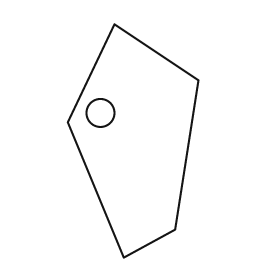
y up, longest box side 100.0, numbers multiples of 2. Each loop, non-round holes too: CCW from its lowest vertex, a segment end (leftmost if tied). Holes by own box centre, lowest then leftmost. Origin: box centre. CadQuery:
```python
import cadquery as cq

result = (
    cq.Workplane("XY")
    .moveTo(-4.0, -50.0)
    .lineTo(18.0, -38.0)
    .lineTo(28.0, 26.0)
    .lineTo(-8.0, 50.0)
    .lineTo(-28.0, 8.0)
    .close()
    .moveTo(-14.0, 12.0)
    .circle(6.0)
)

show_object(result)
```